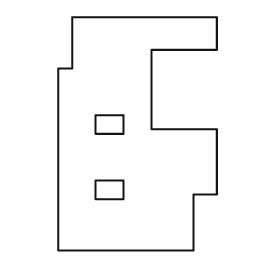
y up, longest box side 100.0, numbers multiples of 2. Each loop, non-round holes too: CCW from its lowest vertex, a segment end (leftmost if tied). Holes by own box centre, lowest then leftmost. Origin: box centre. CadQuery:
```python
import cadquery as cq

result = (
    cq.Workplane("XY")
    .moveTo(-34.0, -50.0)
    .lineTo(24.0, -50.0)
    .lineTo(24.0, -26.0)
    .lineTo(34.0, -26.0)
    .lineTo(34.0, 2.0)
    .lineTo(6.0, 2.0)
    .lineTo(6.0, 36.0)
    .lineTo(34.0, 36.0)
    .lineTo(34.0, 50.0)
    .lineTo(-28.0, 50.0)
    .lineTo(-28.0, 28.0)
    .lineTo(-34.0, 28.0)
    .close()
    .moveTo(-18.0, -28.0)
    .lineTo(-6.0, -28.0)
    .lineTo(-6.0, -20.0)
    .lineTo(-18.0, -20.0)
    .close()
    .moveTo(-18.0, 0.0)
    .lineTo(-6.0, 0.0)
    .lineTo(-6.0, 8.0)
    .lineTo(-18.0, 8.0)
    .close()
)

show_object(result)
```